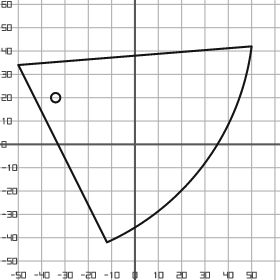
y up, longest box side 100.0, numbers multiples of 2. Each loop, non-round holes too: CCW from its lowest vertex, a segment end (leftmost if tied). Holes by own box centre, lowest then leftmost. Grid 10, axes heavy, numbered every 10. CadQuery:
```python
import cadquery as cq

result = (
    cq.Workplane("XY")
    .moveTo(-12.0, -42.0)
    .threePointArc((30.0, -8.0), (50.0, 42.0))
    .lineTo(-50.0, 34.0)
    .close()
    .moveTo(-34.0, 20.0)
    .circle(2.0)
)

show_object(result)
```